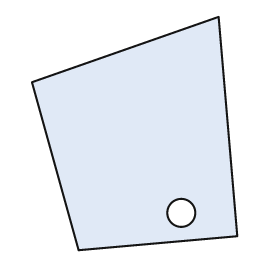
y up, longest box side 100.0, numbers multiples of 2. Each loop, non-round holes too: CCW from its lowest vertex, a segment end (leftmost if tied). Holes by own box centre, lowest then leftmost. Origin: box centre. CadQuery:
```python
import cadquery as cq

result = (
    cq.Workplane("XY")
    .moveTo(-24.0, -50.0)
    .lineTo(44.0, -44.0)
    .lineTo(36.0, 50.0)
    .lineTo(-44.0, 22.0)
    .close()
    .moveTo(20.0, -34.0)
    .circle(6.0)
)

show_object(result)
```